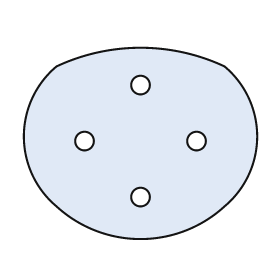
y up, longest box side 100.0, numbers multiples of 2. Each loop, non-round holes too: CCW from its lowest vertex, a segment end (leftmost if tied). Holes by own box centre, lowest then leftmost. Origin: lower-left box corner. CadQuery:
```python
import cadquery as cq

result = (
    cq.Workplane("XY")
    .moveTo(14.0, 14.0)
    .threePointArc((50.0, 0.0), (86.0, 14.0))
    .threePointArc((100.0, 44.0), (86.0, 74.0))
    .threePointArc((50.0, 82.0), (14.0, 74.0))
    .threePointArc((0.0, 44.0), (14.0, 14.0))
    .close()
    .moveTo(50.0, 18.0)
    .circle(4.0)
    .moveTo(26.0, 42.0)
    .circle(4.0)
    .moveTo(74.0, 42.0)
    .circle(4.0)
    .moveTo(50.0, 66.0)
    .circle(4.0)
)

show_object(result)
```